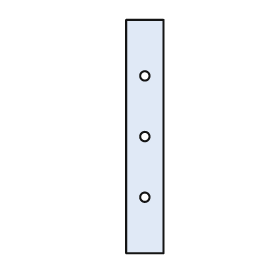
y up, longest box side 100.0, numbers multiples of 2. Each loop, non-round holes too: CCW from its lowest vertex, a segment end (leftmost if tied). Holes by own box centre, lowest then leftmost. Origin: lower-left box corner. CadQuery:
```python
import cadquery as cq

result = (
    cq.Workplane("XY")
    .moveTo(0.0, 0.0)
    .lineTo(16.0, 0.0)
    .lineTo(16.0, 100.0)
    .lineTo(0.0, 100.0)
    .close()
    .moveTo(8.0, 24.0)
    .circle(2.0)
    .moveTo(8.0, 50.0)
    .circle(2.0)
    .moveTo(8.0, 76.0)
    .circle(2.0)
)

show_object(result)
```